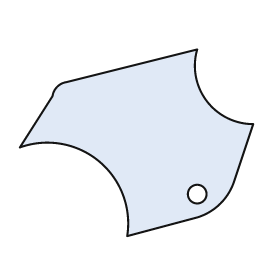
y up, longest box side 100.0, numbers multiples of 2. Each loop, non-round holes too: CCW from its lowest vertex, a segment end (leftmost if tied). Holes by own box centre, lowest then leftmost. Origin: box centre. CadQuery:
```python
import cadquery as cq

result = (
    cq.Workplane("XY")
    .moveTo(-4.0, -40.0)
    .lineTo(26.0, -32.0)
    .threePointArc((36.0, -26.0), (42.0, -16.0))
    .lineTo(50.0, 8.0)
    .threePointArc((30.0, 18.0), (26.0, 40.0))
    .lineTo(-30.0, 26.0)
    .threePointArc((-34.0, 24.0), (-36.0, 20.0))
    .lineTo(-50.0, -2.0)
    .threePointArc((-16.0, -8.0), (-4.0, -40.0))
    .close()
    .moveTo(26.0, -22.0)
    .circle(4.0)
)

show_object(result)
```